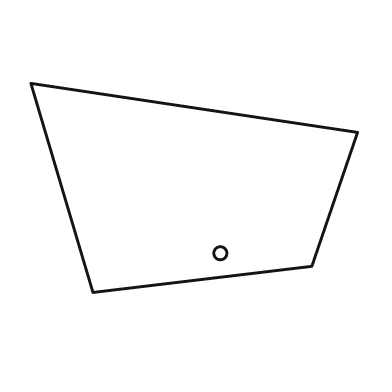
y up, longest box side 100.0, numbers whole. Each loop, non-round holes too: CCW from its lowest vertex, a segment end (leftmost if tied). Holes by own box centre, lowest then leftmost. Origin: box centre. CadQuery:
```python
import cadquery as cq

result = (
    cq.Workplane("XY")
    .moveTo(-31.0, -32.0)
    .lineTo(36.0, -24.0)
    .lineTo(50.0, 17.0)
    .lineTo(-50.0, 32.0)
    .close()
    .moveTo(8.0, -20.0)
    .circle(2.0)
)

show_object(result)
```